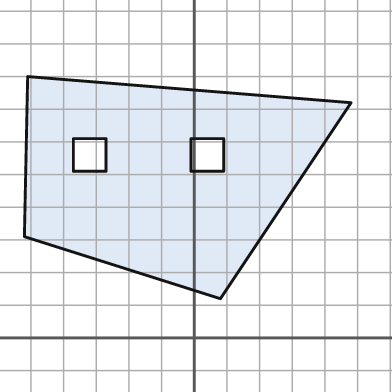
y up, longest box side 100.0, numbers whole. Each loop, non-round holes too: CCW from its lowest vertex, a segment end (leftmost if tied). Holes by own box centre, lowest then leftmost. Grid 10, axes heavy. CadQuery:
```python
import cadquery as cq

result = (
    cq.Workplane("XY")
    .moveTo(8.0, 12.0)
    .lineTo(48.0, 72.0)
    .lineTo(-51.0, 80.0)
    .lineTo(-52.0, 31.0)
    .close()
    .moveTo(-37.0, 51.0)
    .lineTo(-27.0, 51.0)
    .lineTo(-27.0, 61.0)
    .lineTo(-37.0, 61.0)
    .close()
    .moveTo(-1.0, 51.0)
    .lineTo(9.0, 51.0)
    .lineTo(9.0, 61.0)
    .lineTo(-1.0, 61.0)
    .close()
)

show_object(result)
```